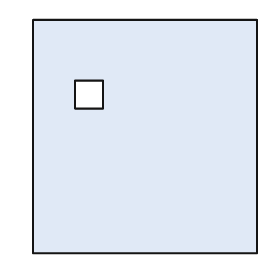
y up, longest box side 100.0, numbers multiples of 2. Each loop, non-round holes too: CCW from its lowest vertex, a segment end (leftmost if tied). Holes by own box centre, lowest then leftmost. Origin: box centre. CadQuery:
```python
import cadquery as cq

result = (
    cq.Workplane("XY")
    .moveTo(-48.0, -50.0)
    .lineTo(48.0, -50.0)
    .lineTo(48.0, 50.0)
    .lineTo(-48.0, 50.0)
    .close()
    .moveTo(-30.0, 12.0)
    .lineTo(-18.0, 12.0)
    .lineTo(-18.0, 24.0)
    .lineTo(-30.0, 24.0)
    .close()
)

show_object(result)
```